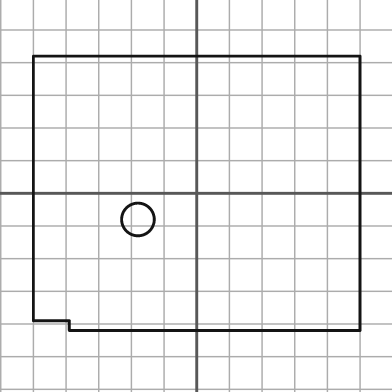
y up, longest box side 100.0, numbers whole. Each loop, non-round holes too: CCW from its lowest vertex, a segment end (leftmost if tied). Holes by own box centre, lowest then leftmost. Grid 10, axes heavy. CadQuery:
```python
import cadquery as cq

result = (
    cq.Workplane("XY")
    .moveTo(-39.0, -42.0)
    .lineTo(50.0, -42.0)
    .lineTo(50.0, 42.0)
    .lineTo(-50.0, 42.0)
    .lineTo(-50.0, -39.0)
    .lineTo(-39.0, -39.0)
    .close()
    .moveTo(-18.0, -8.0)
    .circle(5.0)
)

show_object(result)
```